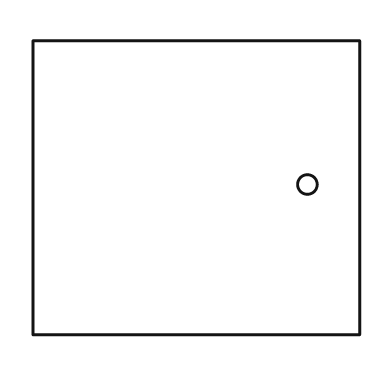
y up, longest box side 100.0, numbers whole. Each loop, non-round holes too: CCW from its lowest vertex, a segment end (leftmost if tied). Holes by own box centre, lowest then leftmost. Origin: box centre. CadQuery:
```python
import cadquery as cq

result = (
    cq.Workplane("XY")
    .moveTo(-50.0, -45.0)
    .lineTo(50.0, -45.0)
    .lineTo(50.0, 45.0)
    .lineTo(-50.0, 45.0)
    .close()
    .moveTo(34.0, 1.0)
    .circle(3.0)
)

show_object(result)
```